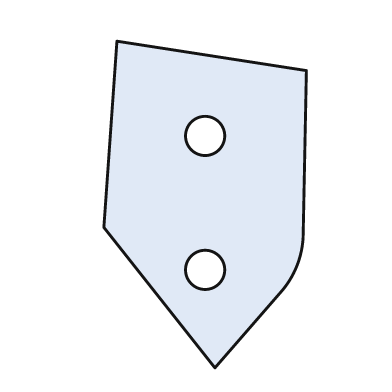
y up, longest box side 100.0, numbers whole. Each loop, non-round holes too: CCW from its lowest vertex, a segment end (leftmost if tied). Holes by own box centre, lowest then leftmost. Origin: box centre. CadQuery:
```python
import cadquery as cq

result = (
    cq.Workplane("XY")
    .moveTo(3.0, -50.0)
    .lineTo(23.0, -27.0)
    .threePointArc((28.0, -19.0), (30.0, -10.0))
    .lineTo(31.0, 41.0)
    .lineTo(-27.0, 50.0)
    .lineTo(-31.0, -7.0)
    .close()
    .moveTo(0.0, -20.0)
    .circle(6.0)
    .moveTo(0.0, 21.0)
    .circle(6.0)
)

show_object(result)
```